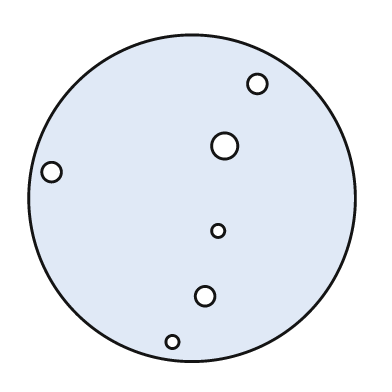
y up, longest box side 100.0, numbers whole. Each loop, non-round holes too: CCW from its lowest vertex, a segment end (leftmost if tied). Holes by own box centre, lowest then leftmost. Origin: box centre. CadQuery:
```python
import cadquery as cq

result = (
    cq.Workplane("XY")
    .moveTo(0.0, 0.0)
    .circle(50.0)
    .moveTo(-6.0, -44.0)
    .circle(2.0)
    .moveTo(4.0, -30.0)
    .circle(3.0)
    .moveTo(8.0, -10.0)
    .circle(2.0)
    .moveTo(-43.0, 8.0)
    .circle(3.0)
    .moveTo(10.0, 16.0)
    .circle(4.0)
    .moveTo(20.0, 35.0)
    .circle(3.0)
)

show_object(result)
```